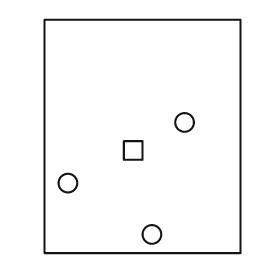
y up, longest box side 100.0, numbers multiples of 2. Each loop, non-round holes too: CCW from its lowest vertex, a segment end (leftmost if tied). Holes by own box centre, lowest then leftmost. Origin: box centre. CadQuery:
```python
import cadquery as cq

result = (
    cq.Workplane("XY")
    .moveTo(-42.0, -50.0)
    .lineTo(42.0, -50.0)
    .lineTo(42.0, 50.0)
    .lineTo(-42.0, 50.0)
    .close()
    .moveTo(4.0, -42.0)
    .circle(4.0)
    .moveTo(-32.0, -20.0)
    .circle(4.0)
    .moveTo(-8.0, -10.0)
    .lineTo(0.0, -10.0)
    .lineTo(0.0, -2.0)
    .lineTo(-8.0, -2.0)
    .close()
    .moveTo(18.0, 6.0)
    .circle(4.0)
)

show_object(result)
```